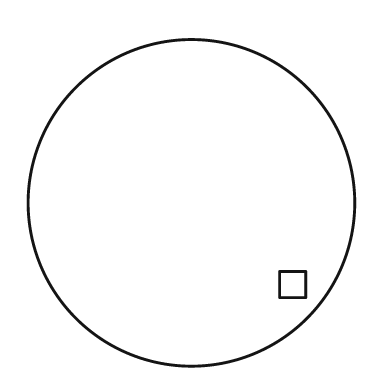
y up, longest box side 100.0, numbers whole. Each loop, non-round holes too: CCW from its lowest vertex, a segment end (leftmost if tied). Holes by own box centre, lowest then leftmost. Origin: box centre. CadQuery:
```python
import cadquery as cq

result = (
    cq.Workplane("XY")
    .moveTo(0.0, 0.0)
    .circle(50.0)
    .moveTo(27.0, -29.0)
    .lineTo(35.0, -29.0)
    .lineTo(35.0, -21.0)
    .lineTo(27.0, -21.0)
    .close()
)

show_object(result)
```